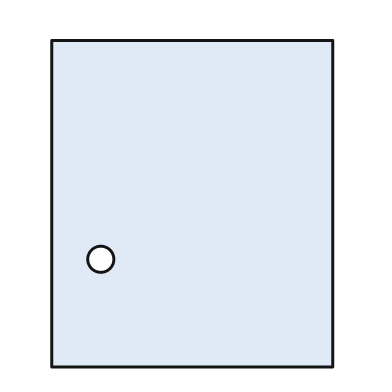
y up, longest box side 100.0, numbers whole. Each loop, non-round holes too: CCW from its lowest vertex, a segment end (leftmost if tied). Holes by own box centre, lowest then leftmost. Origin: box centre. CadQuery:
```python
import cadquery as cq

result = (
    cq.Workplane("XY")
    .moveTo(-43.0, -50.0)
    .lineTo(43.0, -50.0)
    .lineTo(43.0, 50.0)
    .lineTo(-43.0, 50.0)
    .close()
    .moveTo(-28.0, -17.0)
    .circle(4.0)
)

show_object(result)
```